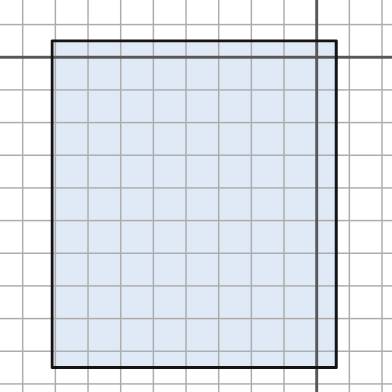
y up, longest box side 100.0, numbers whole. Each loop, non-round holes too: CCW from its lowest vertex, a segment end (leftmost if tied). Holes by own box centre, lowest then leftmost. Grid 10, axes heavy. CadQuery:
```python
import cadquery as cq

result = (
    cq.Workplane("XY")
    .moveTo(-81.0, -95.0)
    .lineTo(6.0, -95.0)
    .lineTo(6.0, 5.0)
    .lineTo(-81.0, 5.0)
    .close()
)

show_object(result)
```